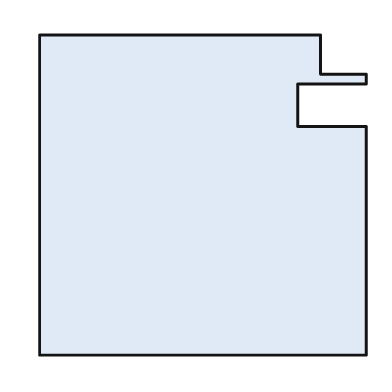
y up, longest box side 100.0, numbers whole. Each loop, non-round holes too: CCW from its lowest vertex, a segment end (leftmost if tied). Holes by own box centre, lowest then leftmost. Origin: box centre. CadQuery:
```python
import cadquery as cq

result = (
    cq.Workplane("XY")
    .moveTo(-50.0, -49.0)
    .lineTo(50.0, -49.0)
    .lineTo(50.0, 21.0)
    .lineTo(29.0, 21.0)
    .lineTo(29.0, 34.0)
    .lineTo(50.0, 34.0)
    .lineTo(50.0, 37.0)
    .lineTo(36.0, 37.0)
    .lineTo(36.0, 49.0)
    .lineTo(-50.0, 49.0)
    .close()
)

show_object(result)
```